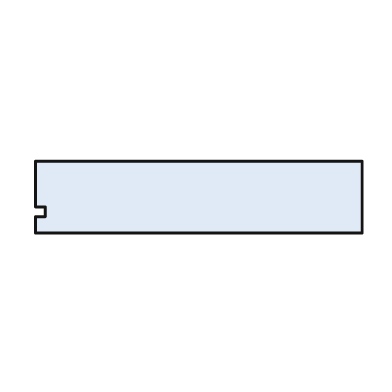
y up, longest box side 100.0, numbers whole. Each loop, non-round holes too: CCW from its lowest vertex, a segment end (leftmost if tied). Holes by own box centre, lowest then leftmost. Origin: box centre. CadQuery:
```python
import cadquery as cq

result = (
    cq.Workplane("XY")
    .moveTo(-50.0, -11.0)
    .lineTo(50.0, -11.0)
    .lineTo(50.0, 11.0)
    .lineTo(-50.0, 11.0)
    .lineTo(-50.0, -3.0)
    .lineTo(-47.0, -3.0)
    .lineTo(-47.0, -6.0)
    .lineTo(-50.0, -6.0)
    .close()
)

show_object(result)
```